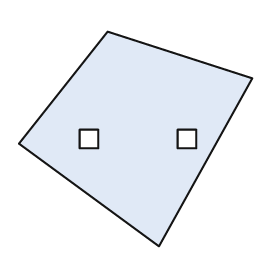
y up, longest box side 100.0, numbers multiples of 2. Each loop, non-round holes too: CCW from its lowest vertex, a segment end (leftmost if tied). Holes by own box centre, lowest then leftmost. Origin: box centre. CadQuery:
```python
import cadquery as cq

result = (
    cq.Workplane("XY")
    .moveTo(10.0, -46.0)
    .lineTo(50.0, 26.0)
    .lineTo(-12.0, 46.0)
    .lineTo(-50.0, -2.0)
    .close()
    .moveTo(-24.0, -4.0)
    .lineTo(-16.0, -4.0)
    .lineTo(-16.0, 4.0)
    .lineTo(-24.0, 4.0)
    .close()
    .moveTo(18.0, -4.0)
    .lineTo(26.0, -4.0)
    .lineTo(26.0, 4.0)
    .lineTo(18.0, 4.0)
    .close()
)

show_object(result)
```